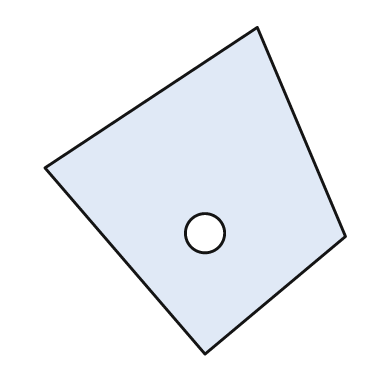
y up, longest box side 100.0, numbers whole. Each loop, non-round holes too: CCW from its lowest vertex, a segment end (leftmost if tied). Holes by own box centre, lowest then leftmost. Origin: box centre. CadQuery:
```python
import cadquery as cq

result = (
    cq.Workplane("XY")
    .moveTo(3.0, -50.0)
    .lineTo(46.0, -14.0)
    .lineTo(19.0, 50.0)
    .lineTo(-46.0, 7.0)
    .close()
    .moveTo(3.0, -13.0)
    .circle(6.0)
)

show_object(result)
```